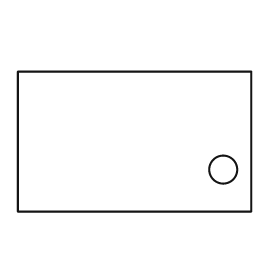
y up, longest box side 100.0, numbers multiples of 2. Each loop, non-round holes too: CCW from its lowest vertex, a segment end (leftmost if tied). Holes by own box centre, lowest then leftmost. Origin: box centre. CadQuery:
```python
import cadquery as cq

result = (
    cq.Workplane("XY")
    .moveTo(-50.0, -30.0)
    .lineTo(50.0, -30.0)
    .lineTo(50.0, 30.0)
    .lineTo(-50.0, 30.0)
    .close()
    .moveTo(38.0, -12.0)
    .circle(6.0)
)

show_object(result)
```